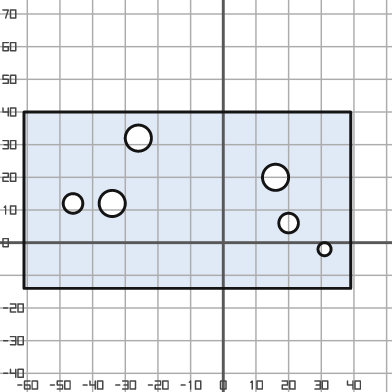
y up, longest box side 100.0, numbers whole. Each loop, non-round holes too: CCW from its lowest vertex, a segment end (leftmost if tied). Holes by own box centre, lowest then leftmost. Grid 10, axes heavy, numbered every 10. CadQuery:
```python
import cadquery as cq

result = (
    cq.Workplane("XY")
    .moveTo(-61.0, -14.0)
    .lineTo(39.0, -14.0)
    .lineTo(39.0, 40.0)
    .lineTo(-61.0, 40.0)
    .close()
    .moveTo(31.0, -2.0)
    .circle(2.0)
    .moveTo(20.0, 6.0)
    .circle(3.0)
    .moveTo(-46.0, 12.0)
    .circle(3.0)
    .moveTo(-34.0, 12.0)
    .circle(4.0)
    .moveTo(16.0, 20.0)
    .circle(4.0)
    .moveTo(-26.0, 32.0)
    .circle(4.0)
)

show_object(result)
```